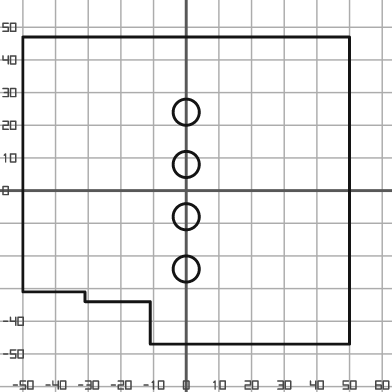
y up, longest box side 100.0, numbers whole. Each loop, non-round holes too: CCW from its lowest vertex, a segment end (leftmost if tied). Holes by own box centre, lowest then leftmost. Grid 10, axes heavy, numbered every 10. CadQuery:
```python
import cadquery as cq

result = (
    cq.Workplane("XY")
    .moveTo(-11.0, -47.0)
    .lineTo(50.0, -47.0)
    .lineTo(50.0, 47.0)
    .lineTo(-50.0, 47.0)
    .lineTo(-50.0, -31.0)
    .lineTo(-31.0, -31.0)
    .lineTo(-31.0, -34.0)
    .lineTo(-11.0, -34.0)
    .close()
    .moveTo(0.0, -24.0)
    .circle(4.0)
    .moveTo(0.0, -8.0)
    .circle(4.0)
    .moveTo(0.0, 8.0)
    .circle(4.0)
    .moveTo(0.0, 24.0)
    .circle(4.0)
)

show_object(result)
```